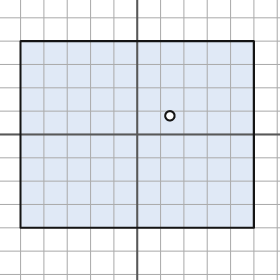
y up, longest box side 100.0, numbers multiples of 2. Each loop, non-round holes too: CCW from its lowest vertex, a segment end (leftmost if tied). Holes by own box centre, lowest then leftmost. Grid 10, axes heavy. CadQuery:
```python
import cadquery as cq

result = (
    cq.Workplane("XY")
    .moveTo(-50.0, -40.0)
    .lineTo(50.0, -40.0)
    .lineTo(50.0, 40.0)
    .lineTo(-50.0, 40.0)
    .close()
    .moveTo(14.0, 8.0)
    .circle(2.0)
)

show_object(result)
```